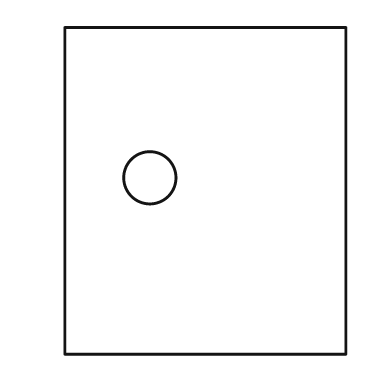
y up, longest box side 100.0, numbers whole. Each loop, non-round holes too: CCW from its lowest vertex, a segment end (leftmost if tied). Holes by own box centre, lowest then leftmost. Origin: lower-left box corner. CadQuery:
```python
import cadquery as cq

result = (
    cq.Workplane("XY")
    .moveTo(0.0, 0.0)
    .lineTo(86.0, 0.0)
    .lineTo(86.0, 100.0)
    .lineTo(0.0, 100.0)
    .close()
    .moveTo(26.0, 54.0)
    .circle(8.0)
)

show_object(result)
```